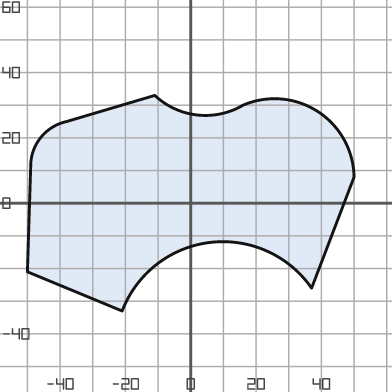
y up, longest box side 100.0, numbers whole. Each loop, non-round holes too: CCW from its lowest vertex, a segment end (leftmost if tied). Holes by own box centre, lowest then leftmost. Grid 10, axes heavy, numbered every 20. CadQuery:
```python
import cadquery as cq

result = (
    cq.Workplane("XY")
    .moveTo(-21.0, -33.0)
    .threePointArc((6.0, -12.0), (37.0, -26.0))
    .lineTo(50.0, 8.0)
    .threePointArc((39.0, 28.0), (16.0, 30.0))
    .threePointArc((2.0, 27.0), (-11.0, 33.0))
    .lineTo(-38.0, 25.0)
    .threePointArc((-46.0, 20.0), (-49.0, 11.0))
    .lineTo(-50.0, -21.0)
    .close()
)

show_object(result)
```